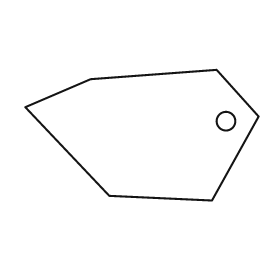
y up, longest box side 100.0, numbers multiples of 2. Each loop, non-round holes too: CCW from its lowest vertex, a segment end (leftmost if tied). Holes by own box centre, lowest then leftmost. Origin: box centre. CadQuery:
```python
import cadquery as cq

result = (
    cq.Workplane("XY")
    .moveTo(30.0, -28.0)
    .lineTo(50.0, 8.0)
    .lineTo(32.0, 28.0)
    .lineTo(-22.0, 24.0)
    .lineTo(-50.0, 12.0)
    .lineTo(-14.0, -26.0)
    .close()
    .moveTo(36.0, 6.0)
    .circle(4.0)
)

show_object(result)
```